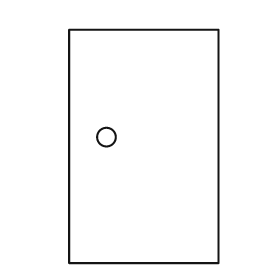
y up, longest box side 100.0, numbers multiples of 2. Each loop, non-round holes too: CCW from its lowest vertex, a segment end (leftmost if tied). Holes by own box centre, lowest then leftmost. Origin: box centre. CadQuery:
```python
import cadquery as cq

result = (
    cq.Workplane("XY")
    .moveTo(-32.0, -50.0)
    .lineTo(32.0, -50.0)
    .lineTo(32.0, 50.0)
    .lineTo(-32.0, 50.0)
    .close()
    .moveTo(-16.0, 4.0)
    .circle(4.0)
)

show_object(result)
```